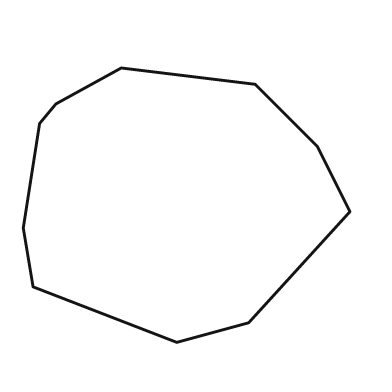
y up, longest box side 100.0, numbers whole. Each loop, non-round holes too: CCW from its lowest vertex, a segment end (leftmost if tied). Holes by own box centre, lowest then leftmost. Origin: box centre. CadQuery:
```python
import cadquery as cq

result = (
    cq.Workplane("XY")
    .moveTo(-3.0, -42.0)
    .lineTo(19.0, -36.0)
    .lineTo(50.0, -2.0)
    .lineTo(40.0, 18.0)
    .lineTo(21.0, 37.0)
    .lineTo(-20.0, 42.0)
    .lineTo(-40.0, 31.0)
    .lineTo(-45.0, 25.0)
    .lineTo(-50.0, -7.0)
    .lineTo(-47.0, -25.0)
    .close()
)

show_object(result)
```